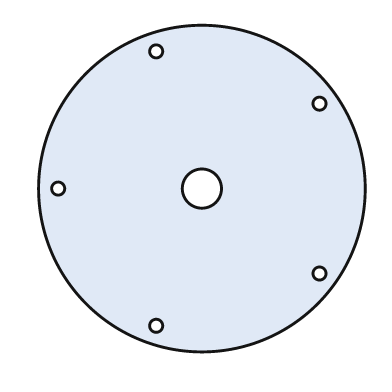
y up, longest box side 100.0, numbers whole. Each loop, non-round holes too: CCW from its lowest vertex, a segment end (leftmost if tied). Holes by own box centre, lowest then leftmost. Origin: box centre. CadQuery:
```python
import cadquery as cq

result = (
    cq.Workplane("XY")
    .moveTo(0.0, 0.0)
    .circle(50.0)
    .moveTo(-14.0, -42.0)
    .circle(2.0)
    .moveTo(36.0, -26.0)
    .circle(2.0)
    .moveTo(-44.0, 0.0)
    .circle(2.0)
    .moveTo(0.0, 0.0)
    .circle(6.0)
    .moveTo(36.0, 26.0)
    .circle(2.0)
    .moveTo(-14.0, 42.0)
    .circle(2.0)
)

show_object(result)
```